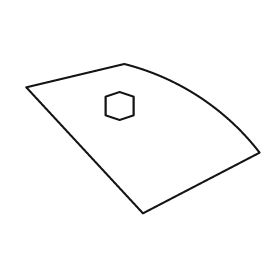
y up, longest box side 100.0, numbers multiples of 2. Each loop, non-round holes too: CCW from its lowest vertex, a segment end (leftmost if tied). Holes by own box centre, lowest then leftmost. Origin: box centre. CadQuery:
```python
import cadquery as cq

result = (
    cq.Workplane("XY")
    .moveTo(0.0, -32.0)
    .lineTo(50.0, -6.0)
    .threePointArc((24.0, 18.0), (-8.0, 32.0))
    .lineTo(-50.0, 22.0)
    .close()
    .moveTo(-10.0, 8.0)
    .lineTo(-4.0, 10.0)
    .lineTo(-4.0, 18.0)
    .lineTo(-10.0, 20.0)
    .lineTo(-16.0, 18.0)
    .lineTo(-16.0, 10.0)
    .close()
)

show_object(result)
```